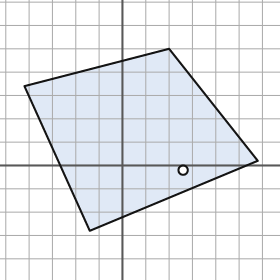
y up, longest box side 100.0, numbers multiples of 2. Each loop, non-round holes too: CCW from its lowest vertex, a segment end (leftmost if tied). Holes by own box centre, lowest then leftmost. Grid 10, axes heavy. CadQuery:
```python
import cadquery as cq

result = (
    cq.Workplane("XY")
    .moveTo(-14.0, -28.0)
    .lineTo(58.0, 2.0)
    .lineTo(20.0, 50.0)
    .lineTo(-42.0, 34.0)
    .close()
    .moveTo(26.0, -2.0)
    .circle(2.0)
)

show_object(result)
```